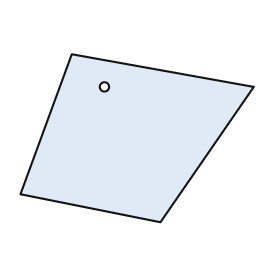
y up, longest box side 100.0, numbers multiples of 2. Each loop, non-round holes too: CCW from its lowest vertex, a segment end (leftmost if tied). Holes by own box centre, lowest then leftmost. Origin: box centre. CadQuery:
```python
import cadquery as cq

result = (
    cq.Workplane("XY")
    .moveTo(10.0, -36.0)
    .lineTo(50.0, 22.0)
    .lineTo(-28.0, 36.0)
    .lineTo(-50.0, -24.0)
    .close()
    .moveTo(-14.0, 22.0)
    .circle(2.0)
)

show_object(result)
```